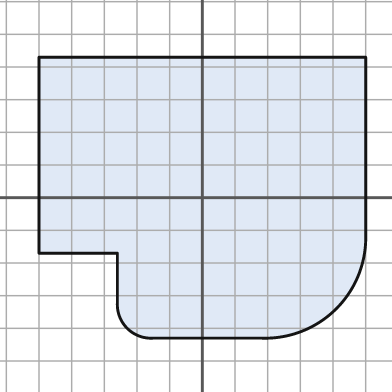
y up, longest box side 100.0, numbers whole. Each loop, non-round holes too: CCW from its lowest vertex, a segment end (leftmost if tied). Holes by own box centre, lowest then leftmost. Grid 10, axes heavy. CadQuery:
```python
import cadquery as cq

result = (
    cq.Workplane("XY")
    .moveTo(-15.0, -43.0)
    .lineTo(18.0, -43.0)
    .threePointArc((41.0, -34.0), (50.0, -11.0))
    .lineTo(50.0, 43.0)
    .lineTo(-50.0, 43.0)
    .lineTo(-50.0, -17.0)
    .lineTo(-26.0, -17.0)
    .lineTo(-26.0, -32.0)
    .threePointArc((-23.0, -40.0), (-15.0, -43.0))
    .close()
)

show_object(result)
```